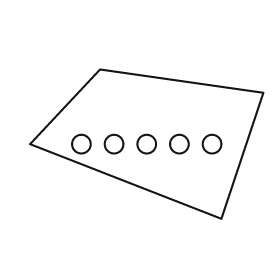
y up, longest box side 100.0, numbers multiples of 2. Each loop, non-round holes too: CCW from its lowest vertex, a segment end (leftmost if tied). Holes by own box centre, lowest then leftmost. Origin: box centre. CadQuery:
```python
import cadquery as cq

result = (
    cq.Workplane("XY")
    .moveTo(32.0, -32.0)
    .lineTo(50.0, 22.0)
    .lineTo(-20.0, 32.0)
    .lineTo(-50.0, 0.0)
    .close()
    .moveTo(-28.0, 0.0)
    .circle(4.0)
    .moveTo(-14.0, 0.0)
    .circle(4.0)
    .moveTo(0.0, 0.0)
    .circle(4.0)
    .moveTo(14.0, 0.0)
    .circle(4.0)
    .moveTo(28.0, 0.0)
    .circle(4.0)
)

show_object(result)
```